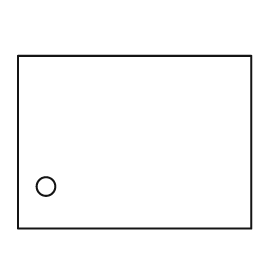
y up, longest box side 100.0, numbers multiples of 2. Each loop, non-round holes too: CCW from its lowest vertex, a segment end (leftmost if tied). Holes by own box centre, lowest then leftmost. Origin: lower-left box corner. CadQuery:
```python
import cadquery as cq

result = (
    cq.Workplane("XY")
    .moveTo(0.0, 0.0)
    .lineTo(100.0, 0.0)
    .lineTo(100.0, 74.0)
    .lineTo(0.0, 74.0)
    .close()
    .moveTo(12.0, 18.0)
    .circle(4.0)
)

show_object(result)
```